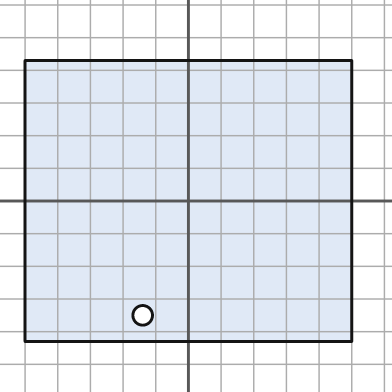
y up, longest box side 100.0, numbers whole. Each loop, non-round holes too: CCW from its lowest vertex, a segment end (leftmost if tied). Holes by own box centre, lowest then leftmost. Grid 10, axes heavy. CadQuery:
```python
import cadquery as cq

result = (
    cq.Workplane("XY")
    .moveTo(-50.0, -43.0)
    .lineTo(50.0, -43.0)
    .lineTo(50.0, 43.0)
    .lineTo(-50.0, 43.0)
    .close()
    .moveTo(-14.0, -35.0)
    .circle(3.0)
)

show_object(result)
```